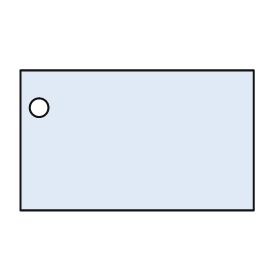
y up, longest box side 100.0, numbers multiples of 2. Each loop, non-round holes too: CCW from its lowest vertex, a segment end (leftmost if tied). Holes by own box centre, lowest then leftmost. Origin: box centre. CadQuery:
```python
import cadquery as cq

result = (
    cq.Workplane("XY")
    .moveTo(-50.0, -30.0)
    .lineTo(50.0, -30.0)
    .lineTo(50.0, 30.0)
    .lineTo(-50.0, 30.0)
    .close()
    .moveTo(-42.0, 14.0)
    .circle(4.0)
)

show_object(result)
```